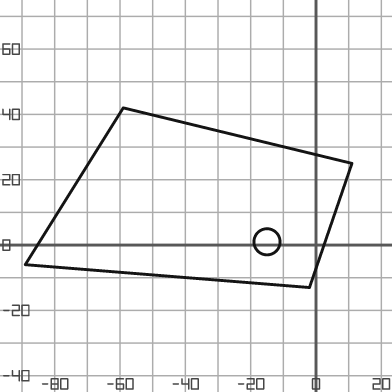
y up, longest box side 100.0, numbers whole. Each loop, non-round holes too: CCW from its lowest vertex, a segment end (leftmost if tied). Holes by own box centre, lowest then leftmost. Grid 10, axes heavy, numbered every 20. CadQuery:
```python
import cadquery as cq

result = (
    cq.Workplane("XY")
    .moveTo(-2.0, -13.0)
    .lineTo(11.0, 25.0)
    .lineTo(-59.0, 42.0)
    .lineTo(-89.0, -6.0)
    .close()
    .moveTo(-15.0, 1.0)
    .circle(4.0)
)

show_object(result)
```